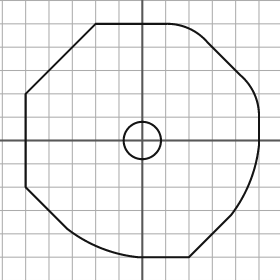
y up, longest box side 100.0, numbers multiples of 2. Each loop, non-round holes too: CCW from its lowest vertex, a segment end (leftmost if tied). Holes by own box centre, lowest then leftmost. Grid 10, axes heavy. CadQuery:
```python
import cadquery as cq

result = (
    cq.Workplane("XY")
    .moveTo(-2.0, -50.0)
    .lineTo(20.0, -50.0)
    .lineTo(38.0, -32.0)
    .threePointArc((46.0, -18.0), (50.0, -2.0))
    .lineTo(50.0, 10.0)
    .threePointArc((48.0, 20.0), (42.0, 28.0))
    .lineTo(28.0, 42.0)
    .threePointArc((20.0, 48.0), (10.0, 50.0))
    .lineTo(-20.0, 50.0)
    .lineTo(-50.0, 20.0)
    .lineTo(-50.0, -20.0)
    .lineTo(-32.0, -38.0)
    .threePointArc((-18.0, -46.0), (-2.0, -50.0))
    .close()
    .moveTo(0.0, 0.0)
    .circle(8.0)
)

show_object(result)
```